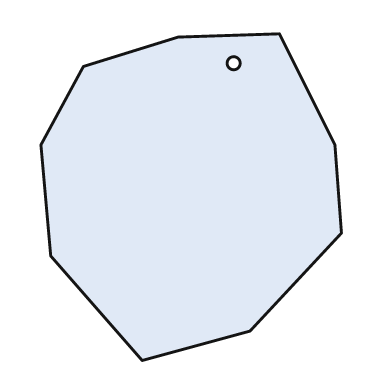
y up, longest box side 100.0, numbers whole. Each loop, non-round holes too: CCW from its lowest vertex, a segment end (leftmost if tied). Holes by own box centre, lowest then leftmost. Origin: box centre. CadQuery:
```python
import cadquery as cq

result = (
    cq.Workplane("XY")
    .moveTo(-15.0, -50.0)
    .lineTo(18.0, -41.0)
    .lineTo(46.0, -11.0)
    .lineTo(44.0, 16.0)
    .lineTo(27.0, 50.0)
    .lineTo(-4.0, 49.0)
    .lineTo(-33.0, 40.0)
    .lineTo(-46.0, 16.0)
    .lineTo(-43.0, -18.0)
    .close()
    .moveTo(13.0, 41.0)
    .circle(2.0)
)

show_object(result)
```